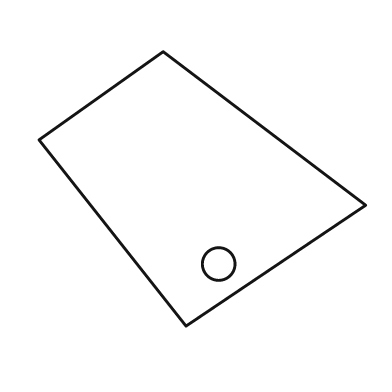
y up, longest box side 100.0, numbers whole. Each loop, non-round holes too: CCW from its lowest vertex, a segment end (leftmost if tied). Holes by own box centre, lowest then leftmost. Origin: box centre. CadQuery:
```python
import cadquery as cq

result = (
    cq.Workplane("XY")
    .moveTo(-5.0, -42.0)
    .lineTo(50.0, -5.0)
    .lineTo(-12.0, 42.0)
    .lineTo(-50.0, 15.0)
    .close()
    .moveTo(5.0, -23.0)
    .circle(5.0)
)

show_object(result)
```